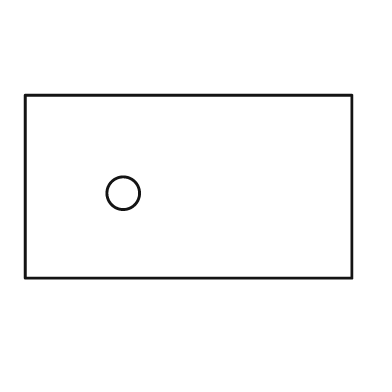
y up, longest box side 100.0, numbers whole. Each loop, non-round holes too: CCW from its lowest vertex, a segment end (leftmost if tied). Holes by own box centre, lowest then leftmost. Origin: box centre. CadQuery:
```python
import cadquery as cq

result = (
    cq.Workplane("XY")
    .moveTo(-50.0, -28.0)
    .lineTo(50.0, -28.0)
    .lineTo(50.0, 28.0)
    .lineTo(-50.0, 28.0)
    .close()
    .moveTo(-20.0, -2.0)
    .circle(5.0)
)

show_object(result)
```